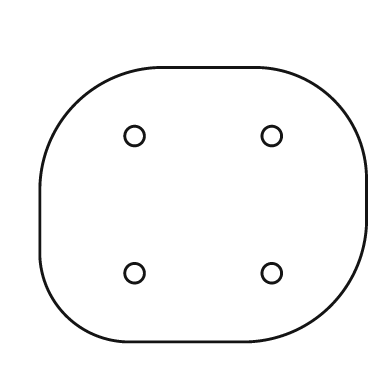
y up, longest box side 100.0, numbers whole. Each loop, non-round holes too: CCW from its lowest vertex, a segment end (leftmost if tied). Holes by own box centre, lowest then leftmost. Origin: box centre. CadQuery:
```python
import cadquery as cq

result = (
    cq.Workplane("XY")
    .moveTo(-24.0, -42.0)
    .lineTo(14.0, -42.0)
    .threePointArc((39.0, -31.0), (50.0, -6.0))
    .lineTo(50.0, 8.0)
    .threePointArc((40.0, 32.0), (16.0, 42.0))
    .lineTo(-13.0, 42.0)
    .threePointArc((-39.0, 31.0), (-50.0, 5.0))
    .lineTo(-50.0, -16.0)
    .threePointArc((-42.0, -34.0), (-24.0, -42.0))
    .close()
    .moveTo(-21.0, -21.0)
    .circle(3.0)
    .moveTo(21.0, -21.0)
    .circle(3.0)
    .moveTo(-21.0, 21.0)
    .circle(3.0)
    .moveTo(21.0, 21.0)
    .circle(3.0)
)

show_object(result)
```